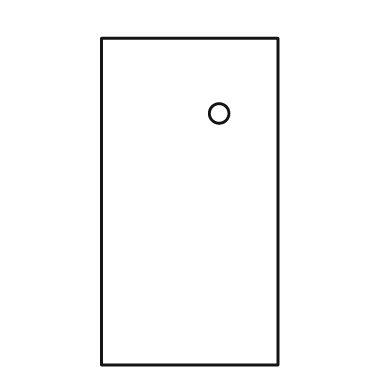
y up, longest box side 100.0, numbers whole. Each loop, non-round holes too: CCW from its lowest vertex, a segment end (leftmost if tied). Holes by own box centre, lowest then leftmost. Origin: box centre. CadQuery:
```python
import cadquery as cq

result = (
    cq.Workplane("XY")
    .moveTo(-27.0, -50.0)
    .lineTo(27.0, -50.0)
    .lineTo(27.0, 50.0)
    .lineTo(-27.0, 50.0)
    .close()
    .moveTo(9.0, 27.0)
    .circle(3.0)
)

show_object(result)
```